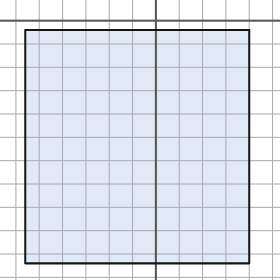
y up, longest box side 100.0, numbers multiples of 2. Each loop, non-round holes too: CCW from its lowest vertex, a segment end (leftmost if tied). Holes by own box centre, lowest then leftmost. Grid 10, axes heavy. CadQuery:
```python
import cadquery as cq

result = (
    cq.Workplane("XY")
    .moveTo(-56.0, -104.0)
    .lineTo(40.0, -104.0)
    .lineTo(40.0, -4.0)
    .lineTo(-56.0, -4.0)
    .close()
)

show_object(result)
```